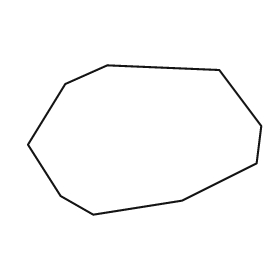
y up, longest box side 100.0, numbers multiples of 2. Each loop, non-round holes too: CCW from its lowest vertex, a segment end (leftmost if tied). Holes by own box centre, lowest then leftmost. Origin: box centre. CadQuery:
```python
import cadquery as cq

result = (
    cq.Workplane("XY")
    .moveTo(-22.0, -32.0)
    .lineTo(16.0, -26.0)
    .lineTo(48.0, -10.0)
    .lineTo(50.0, 6.0)
    .lineTo(32.0, 30.0)
    .lineTo(-16.0, 32.0)
    .lineTo(-34.0, 24.0)
    .lineTo(-50.0, -2.0)
    .lineTo(-36.0, -24.0)
    .close()
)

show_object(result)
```